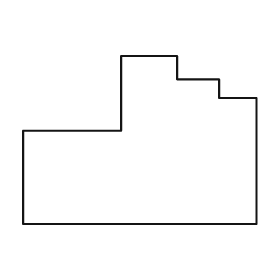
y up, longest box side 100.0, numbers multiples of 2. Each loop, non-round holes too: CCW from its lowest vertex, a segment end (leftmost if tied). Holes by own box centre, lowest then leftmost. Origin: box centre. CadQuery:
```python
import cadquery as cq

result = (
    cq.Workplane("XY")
    .moveTo(-50.0, -36.0)
    .lineTo(50.0, -36.0)
    .lineTo(50.0, 18.0)
    .lineTo(34.0, 18.0)
    .lineTo(34.0, 26.0)
    .lineTo(16.0, 26.0)
    .lineTo(16.0, 36.0)
    .lineTo(-8.0, 36.0)
    .lineTo(-8.0, 4.0)
    .lineTo(-50.0, 4.0)
    .close()
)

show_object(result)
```